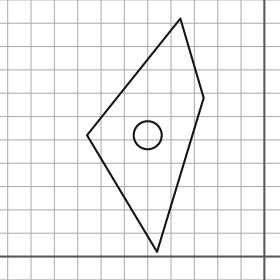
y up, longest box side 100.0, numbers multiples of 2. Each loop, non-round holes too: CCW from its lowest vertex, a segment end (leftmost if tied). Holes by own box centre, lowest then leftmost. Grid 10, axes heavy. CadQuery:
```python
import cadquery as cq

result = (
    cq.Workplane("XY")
    .moveTo(-46.0, 2.0)
    .lineTo(-26.0, 68.0)
    .lineTo(-36.0, 102.0)
    .lineTo(-76.0, 52.0)
    .close()
    .moveTo(-50.0, 52.0)
    .circle(6.0)
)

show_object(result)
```